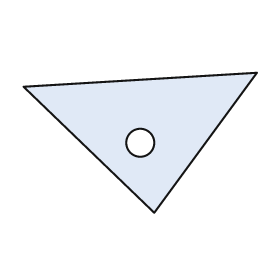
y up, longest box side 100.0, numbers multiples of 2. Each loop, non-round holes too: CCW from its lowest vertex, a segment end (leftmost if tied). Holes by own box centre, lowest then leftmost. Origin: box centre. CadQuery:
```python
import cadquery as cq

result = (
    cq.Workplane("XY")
    .moveTo(6.0, -30.0)
    .lineTo(50.0, 30.0)
    .lineTo(-50.0, 24.0)
    .close()
    .moveTo(0.0, 0.0)
    .circle(6.0)
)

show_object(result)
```